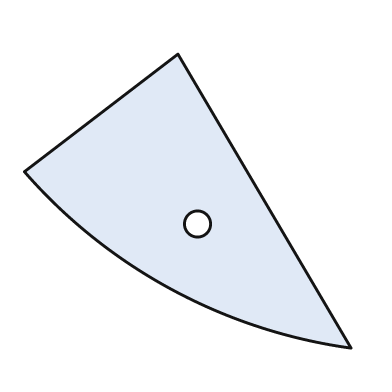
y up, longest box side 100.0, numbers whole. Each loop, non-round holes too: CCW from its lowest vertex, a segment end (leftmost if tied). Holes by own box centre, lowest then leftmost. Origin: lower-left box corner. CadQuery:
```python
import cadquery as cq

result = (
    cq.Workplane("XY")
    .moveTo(100.0, 0.0)
    .lineTo(47.0, 90.0)
    .lineTo(0.0, 54.0)
    .threePointArc((45.0, 18.0), (100.0, 0.0))
    .close()
    .moveTo(53.0, 38.0)
    .circle(4.0)
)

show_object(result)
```